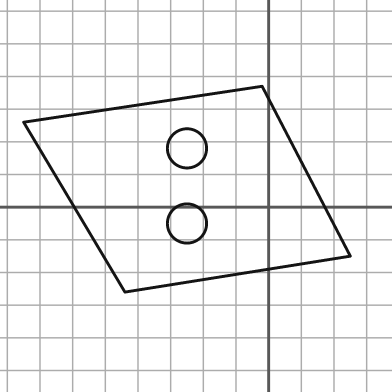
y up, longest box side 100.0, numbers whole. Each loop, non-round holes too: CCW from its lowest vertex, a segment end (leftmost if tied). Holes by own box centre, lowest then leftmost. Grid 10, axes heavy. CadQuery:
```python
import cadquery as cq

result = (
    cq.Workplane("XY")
    .moveTo(-44.0, -26.0)
    .lineTo(25.0, -15.0)
    .lineTo(-2.0, 37.0)
    .lineTo(-75.0, 26.0)
    .close()
    .moveTo(-25.0, -5.0)
    .circle(6.0)
    .moveTo(-25.0, 18.0)
    .circle(6.0)
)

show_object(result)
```